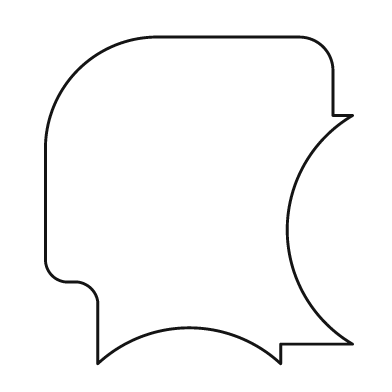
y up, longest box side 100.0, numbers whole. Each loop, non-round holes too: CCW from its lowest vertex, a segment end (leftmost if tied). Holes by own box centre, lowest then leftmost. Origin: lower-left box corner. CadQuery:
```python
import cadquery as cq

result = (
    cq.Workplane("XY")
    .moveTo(16.0, 0.0)
    .threePointArc((44.0, 11.0), (72.0, 0.0))
    .lineTo(72.0, 6.0)
    .lineTo(94.0, 6.0)
    .threePointArc((74.0, 41.0), (94.0, 76.0))
    .lineTo(88.0, 76.0)
    .lineTo(88.0, 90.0)
    .threePointArc((85.0, 97.0), (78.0, 100.0))
    .lineTo(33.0, 100.0)
    .threePointArc((10.0, 90.0), (0.0, 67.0))
    .lineTo(0.0, 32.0)
    .threePointArc((2.0, 27.0), (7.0, 25.0))
    .lineTo(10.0, 25.0)
    .threePointArc((14.0, 23.0), (16.0, 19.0))
    .close()
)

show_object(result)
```